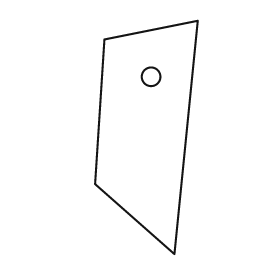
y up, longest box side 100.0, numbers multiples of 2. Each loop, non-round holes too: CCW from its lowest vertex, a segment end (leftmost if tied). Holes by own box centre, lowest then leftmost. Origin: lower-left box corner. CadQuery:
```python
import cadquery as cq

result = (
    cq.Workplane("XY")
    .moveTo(34.0, 0.0)
    .lineTo(44.0, 100.0)
    .lineTo(4.0, 92.0)
    .lineTo(0.0, 30.0)
    .close()
    .moveTo(24.0, 76.0)
    .circle(4.0)
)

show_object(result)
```